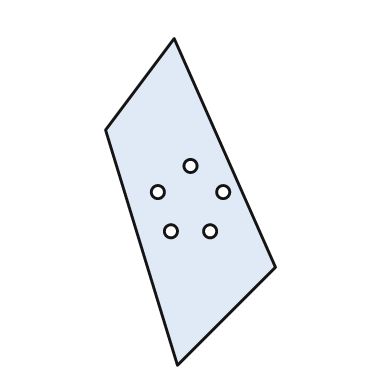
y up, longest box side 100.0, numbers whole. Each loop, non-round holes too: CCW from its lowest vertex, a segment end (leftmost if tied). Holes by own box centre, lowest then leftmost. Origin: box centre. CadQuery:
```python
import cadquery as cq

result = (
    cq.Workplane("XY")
    .moveTo(-4.0, -50.0)
    .lineTo(26.0, -20.0)
    .lineTo(-5.0, 50.0)
    .lineTo(-26.0, 22.0)
    .close()
    .moveTo(-6.0, -9.0)
    .circle(2.0)
    .moveTo(6.0, -9.0)
    .circle(2.0)
    .moveTo(-10.0, 3.0)
    .circle(2.0)
    .moveTo(10.0, 3.0)
    .circle(2.0)
    .moveTo(0.0, 11.0)
    .circle(2.0)
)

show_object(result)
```